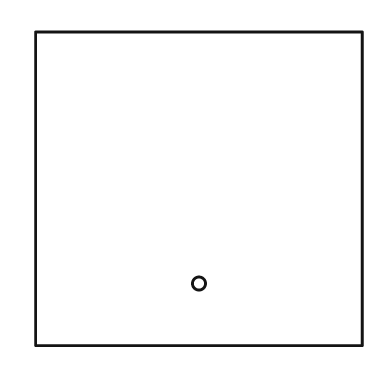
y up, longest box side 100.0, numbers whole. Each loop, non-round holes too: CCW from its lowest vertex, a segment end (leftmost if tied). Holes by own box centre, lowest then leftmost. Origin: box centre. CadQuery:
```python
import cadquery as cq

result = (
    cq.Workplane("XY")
    .moveTo(-50.0, -48.0)
    .lineTo(50.0, -48.0)
    .lineTo(50.0, 48.0)
    .lineTo(-50.0, 48.0)
    .close()
    .moveTo(0.0, -29.0)
    .circle(2.0)
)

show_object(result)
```